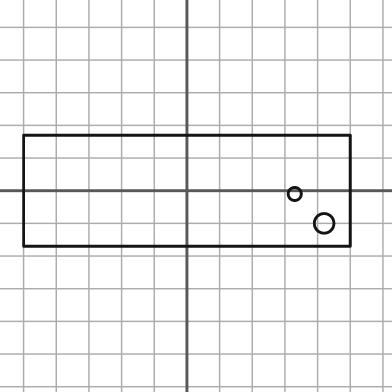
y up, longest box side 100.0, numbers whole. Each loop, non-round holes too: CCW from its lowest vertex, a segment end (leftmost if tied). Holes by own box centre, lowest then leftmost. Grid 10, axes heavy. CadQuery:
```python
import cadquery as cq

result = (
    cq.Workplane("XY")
    .moveTo(-50.0, -17.0)
    .lineTo(50.0, -17.0)
    .lineTo(50.0, 17.0)
    .lineTo(-50.0, 17.0)
    .close()
    .moveTo(42.0, -10.0)
    .circle(3.0)
    .moveTo(33.0, -1.0)
    .circle(2.0)
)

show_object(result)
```